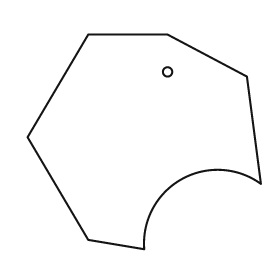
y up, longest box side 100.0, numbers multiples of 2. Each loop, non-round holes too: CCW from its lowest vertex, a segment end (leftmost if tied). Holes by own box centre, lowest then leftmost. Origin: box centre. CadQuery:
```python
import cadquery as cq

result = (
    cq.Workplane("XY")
    .moveTo(0.0, -46.0)
    .threePointArc((16.0, -16.0), (50.0, -18.0))
    .lineTo(44.0, 28.0)
    .lineTo(10.0, 46.0)
    .lineTo(-24.0, 46.0)
    .lineTo(-50.0, 2.0)
    .lineTo(-24.0, -42.0)
    .close()
    .moveTo(10.0, 30.0)
    .circle(2.0)
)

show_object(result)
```